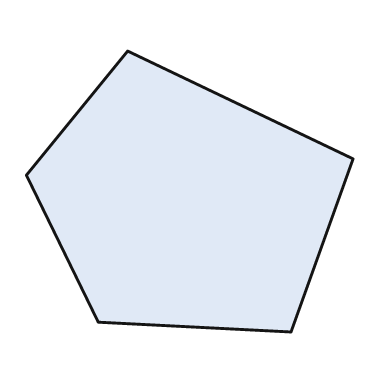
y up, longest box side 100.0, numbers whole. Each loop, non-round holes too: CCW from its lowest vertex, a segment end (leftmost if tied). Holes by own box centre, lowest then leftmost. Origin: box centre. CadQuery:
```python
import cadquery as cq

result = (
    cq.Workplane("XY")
    .moveTo(31.0, -43.0)
    .lineTo(50.0, 10.0)
    .lineTo(-19.0, 43.0)
    .lineTo(-50.0, 5.0)
    .lineTo(-28.0, -40.0)
    .close()
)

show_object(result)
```